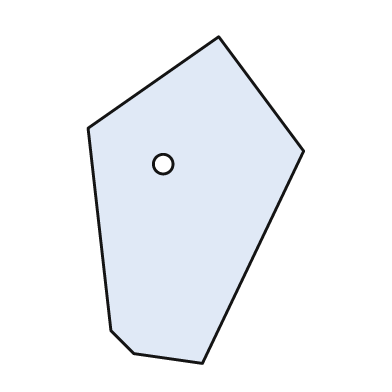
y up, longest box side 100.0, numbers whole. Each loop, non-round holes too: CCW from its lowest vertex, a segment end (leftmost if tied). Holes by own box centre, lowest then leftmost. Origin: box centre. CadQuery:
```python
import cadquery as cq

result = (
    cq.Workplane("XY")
    .moveTo(2.0, -50.0)
    .lineTo(33.0, 15.0)
    .lineTo(7.0, 50.0)
    .lineTo(-33.0, 22.0)
    .lineTo(-26.0, -40.0)
    .lineTo(-19.0, -47.0)
    .close()
    .moveTo(-10.0, 11.0)
    .circle(3.0)
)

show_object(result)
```